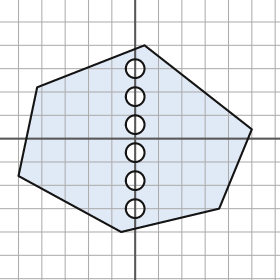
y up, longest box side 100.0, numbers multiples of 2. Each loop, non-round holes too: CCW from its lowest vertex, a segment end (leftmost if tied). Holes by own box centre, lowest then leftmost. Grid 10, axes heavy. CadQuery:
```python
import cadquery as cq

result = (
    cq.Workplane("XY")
    .moveTo(-6.0, -40.0)
    .lineTo(36.0, -30.0)
    .lineTo(50.0, 4.0)
    .lineTo(4.0, 40.0)
    .lineTo(-42.0, 22.0)
    .lineTo(-50.0, -16.0)
    .close()
    .moveTo(0.0, -30.0)
    .circle(4.0)
    .moveTo(0.0, -18.0)
    .circle(4.0)
    .moveTo(0.0, -6.0)
    .circle(4.0)
    .moveTo(0.0, 6.0)
    .circle(4.0)
    .moveTo(0.0, 18.0)
    .circle(4.0)
    .moveTo(0.0, 30.0)
    .circle(4.0)
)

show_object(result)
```